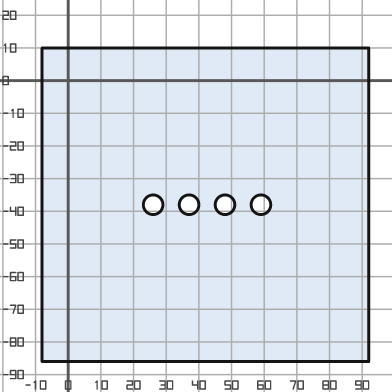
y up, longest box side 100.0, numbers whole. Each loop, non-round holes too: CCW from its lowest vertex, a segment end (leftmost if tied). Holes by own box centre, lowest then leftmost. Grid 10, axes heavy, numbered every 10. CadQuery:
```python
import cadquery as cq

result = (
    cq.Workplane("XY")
    .moveTo(-8.0, -86.0)
    .lineTo(92.0, -86.0)
    .lineTo(92.0, 10.0)
    .lineTo(-8.0, 10.0)
    .close()
    .moveTo(26.0, -38.0)
    .circle(3.0)
    .moveTo(37.0, -38.0)
    .circle(3.0)
    .moveTo(48.0, -38.0)
    .circle(3.0)
    .moveTo(59.0, -38.0)
    .circle(3.0)
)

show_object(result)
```